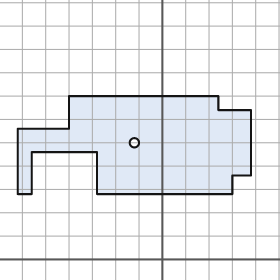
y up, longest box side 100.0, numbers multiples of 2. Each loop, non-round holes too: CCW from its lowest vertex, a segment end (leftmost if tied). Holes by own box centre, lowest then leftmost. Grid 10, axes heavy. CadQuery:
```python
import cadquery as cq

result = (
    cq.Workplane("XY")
    .moveTo(-62.0, 28.0)
    .lineTo(-56.0, 28.0)
    .lineTo(-56.0, 46.0)
    .lineTo(-28.0, 46.0)
    .lineTo(-28.0, 28.0)
    .lineTo(30.0, 28.0)
    .lineTo(30.0, 36.0)
    .lineTo(38.0, 36.0)
    .lineTo(38.0, 64.0)
    .lineTo(24.0, 64.0)
    .lineTo(24.0, 70.0)
    .lineTo(-40.0, 70.0)
    .lineTo(-40.0, 56.0)
    .lineTo(-62.0, 56.0)
    .close()
    .moveTo(-12.0, 50.0)
    .circle(2.0)
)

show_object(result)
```